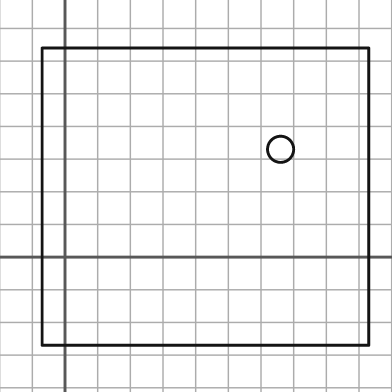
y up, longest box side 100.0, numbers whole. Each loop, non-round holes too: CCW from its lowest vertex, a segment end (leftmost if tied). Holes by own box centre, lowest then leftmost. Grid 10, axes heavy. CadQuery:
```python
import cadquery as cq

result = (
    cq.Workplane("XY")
    .moveTo(-7.0, -27.0)
    .lineTo(93.0, -27.0)
    .lineTo(93.0, 64.0)
    .lineTo(-7.0, 64.0)
    .close()
    .moveTo(66.0, 33.0)
    .circle(4.0)
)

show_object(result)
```